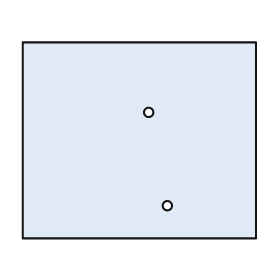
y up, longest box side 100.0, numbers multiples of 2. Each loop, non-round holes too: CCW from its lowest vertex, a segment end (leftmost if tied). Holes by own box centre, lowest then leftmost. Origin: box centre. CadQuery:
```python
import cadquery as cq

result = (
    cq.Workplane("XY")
    .moveTo(-50.0, -42.0)
    .lineTo(50.0, -42.0)
    .lineTo(50.0, 42.0)
    .lineTo(-50.0, 42.0)
    .close()
    .moveTo(12.0, -28.0)
    .circle(2.0)
    .moveTo(4.0, 12.0)
    .circle(2.0)
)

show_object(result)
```